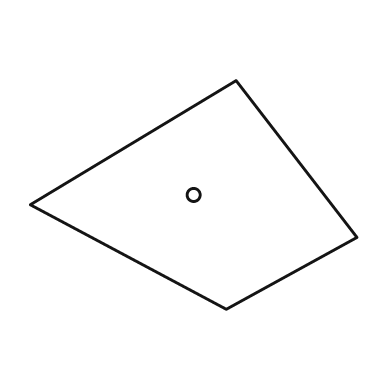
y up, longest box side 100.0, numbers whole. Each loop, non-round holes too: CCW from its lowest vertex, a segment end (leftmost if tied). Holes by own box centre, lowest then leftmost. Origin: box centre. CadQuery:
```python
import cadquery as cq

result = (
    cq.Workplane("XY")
    .moveTo(10.0, -35.0)
    .lineTo(50.0, -13.0)
    .lineTo(13.0, 35.0)
    .lineTo(-50.0, -3.0)
    .close()
    .moveTo(0.0, 0.0)
    .circle(2.0)
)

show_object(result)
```